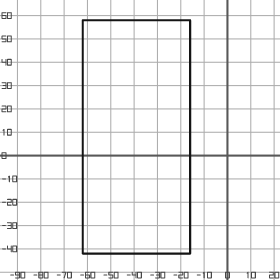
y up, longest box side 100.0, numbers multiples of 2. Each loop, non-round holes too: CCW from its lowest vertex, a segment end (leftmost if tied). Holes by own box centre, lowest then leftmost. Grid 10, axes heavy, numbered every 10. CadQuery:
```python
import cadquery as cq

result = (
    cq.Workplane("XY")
    .moveTo(-62.0, -42.0)
    .lineTo(-16.0, -42.0)
    .lineTo(-16.0, 58.0)
    .lineTo(-62.0, 58.0)
    .close()
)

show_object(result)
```